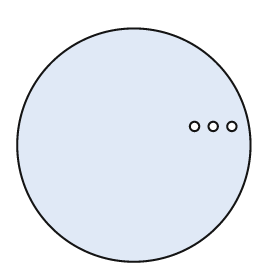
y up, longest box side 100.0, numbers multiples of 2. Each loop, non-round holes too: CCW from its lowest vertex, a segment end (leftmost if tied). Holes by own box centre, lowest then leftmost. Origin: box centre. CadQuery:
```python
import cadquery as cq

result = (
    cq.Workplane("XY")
    .moveTo(0.0, 0.0)
    .circle(50.0)
    .moveTo(26.0, 8.0)
    .circle(2.0)
    .moveTo(34.0, 8.0)
    .circle(2.0)
    .moveTo(42.0, 8.0)
    .circle(2.0)
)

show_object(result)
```